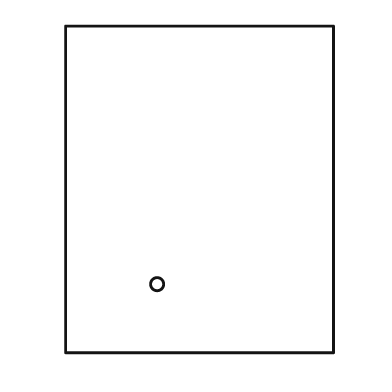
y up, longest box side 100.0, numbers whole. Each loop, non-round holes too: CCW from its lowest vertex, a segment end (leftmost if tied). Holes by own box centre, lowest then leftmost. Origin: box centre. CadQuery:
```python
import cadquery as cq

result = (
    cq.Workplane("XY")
    .moveTo(-41.0, -50.0)
    .lineTo(41.0, -50.0)
    .lineTo(41.0, 50.0)
    .lineTo(-41.0, 50.0)
    .close()
    .moveTo(-13.0, -29.0)
    .circle(2.0)
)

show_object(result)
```